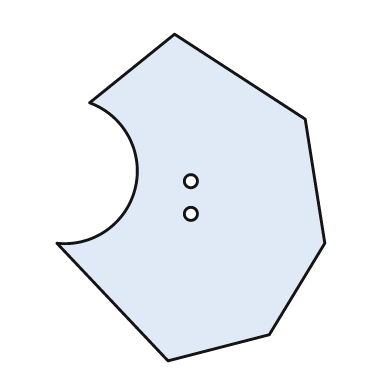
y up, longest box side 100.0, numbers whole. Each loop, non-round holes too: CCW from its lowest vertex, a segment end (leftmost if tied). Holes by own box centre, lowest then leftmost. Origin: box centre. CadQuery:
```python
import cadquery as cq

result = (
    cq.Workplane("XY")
    .moveTo(-7.0, -50.0)
    .lineTo(24.0, -42.0)
    .lineTo(41.0, -14.0)
    .lineTo(35.0, 24.0)
    .lineTo(-5.0, 50.0)
    .lineTo(-31.0, 29.0)
    .threePointArc((-17.0, 3.0), (-41.0, -14.0))
    .close()
    .moveTo(0.0, -5.0)
    .circle(2.0)
    .moveTo(0.0, 5.0)
    .circle(2.0)
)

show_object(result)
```